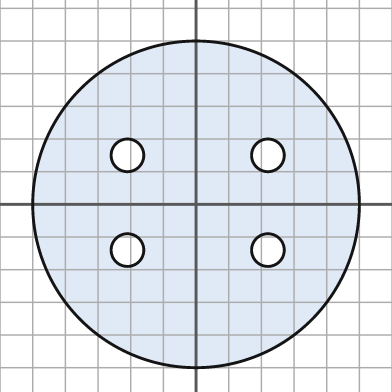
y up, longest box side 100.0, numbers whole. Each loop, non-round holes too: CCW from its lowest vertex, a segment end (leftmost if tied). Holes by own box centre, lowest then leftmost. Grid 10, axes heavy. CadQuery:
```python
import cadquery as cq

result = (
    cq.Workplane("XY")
    .moveTo(0.0, 0.0)
    .circle(50.0)
    .moveTo(-21.0, -14.0)
    .circle(5.0)
    .moveTo(22.0, -14.0)
    .circle(5.0)
    .moveTo(-21.0, 15.0)
    .circle(5.0)
    .moveTo(22.0, 15.0)
    .circle(5.0)
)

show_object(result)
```